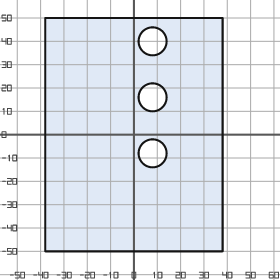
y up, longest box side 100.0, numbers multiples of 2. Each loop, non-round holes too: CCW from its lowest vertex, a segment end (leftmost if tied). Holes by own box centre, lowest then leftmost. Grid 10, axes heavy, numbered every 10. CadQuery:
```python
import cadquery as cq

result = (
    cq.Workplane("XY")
    .moveTo(-38.0, -50.0)
    .lineTo(38.0, -50.0)
    .lineTo(38.0, 50.0)
    .lineTo(-38.0, 50.0)
    .close()
    .moveTo(8.0, -8.0)
    .circle(6.0)
    .moveTo(8.0, 16.0)
    .circle(6.0)
    .moveTo(8.0, 40.0)
    .circle(6.0)
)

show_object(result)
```